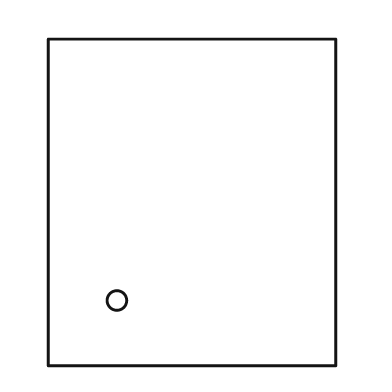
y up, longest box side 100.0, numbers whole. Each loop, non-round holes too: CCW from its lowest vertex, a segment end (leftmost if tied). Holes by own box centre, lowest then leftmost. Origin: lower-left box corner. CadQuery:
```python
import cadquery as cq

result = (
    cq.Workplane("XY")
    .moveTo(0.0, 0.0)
    .lineTo(88.0, 0.0)
    .lineTo(88.0, 100.0)
    .lineTo(0.0, 100.0)
    .close()
    .moveTo(21.0, 20.0)
    .circle(3.0)
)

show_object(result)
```